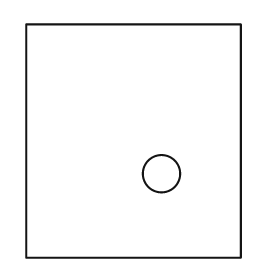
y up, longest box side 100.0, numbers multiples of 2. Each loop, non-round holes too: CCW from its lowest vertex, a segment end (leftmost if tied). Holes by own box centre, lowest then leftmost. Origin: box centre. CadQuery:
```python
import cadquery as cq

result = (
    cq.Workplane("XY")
    .moveTo(-46.0, -50.0)
    .lineTo(46.0, -50.0)
    .lineTo(46.0, 50.0)
    .lineTo(-46.0, 50.0)
    .close()
    .moveTo(12.0, -14.0)
    .circle(8.0)
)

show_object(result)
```